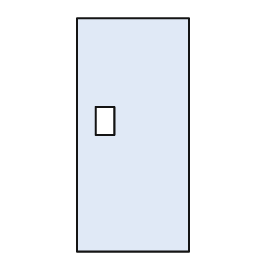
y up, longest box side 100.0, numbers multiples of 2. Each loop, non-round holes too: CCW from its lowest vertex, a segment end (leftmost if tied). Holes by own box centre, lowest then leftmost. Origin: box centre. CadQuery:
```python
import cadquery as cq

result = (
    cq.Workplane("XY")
    .moveTo(-24.0, -50.0)
    .lineTo(24.0, -50.0)
    .lineTo(24.0, 50.0)
    .lineTo(-24.0, 50.0)
    .close()
    .moveTo(-16.0, 0.0)
    .lineTo(-8.0, 0.0)
    .lineTo(-8.0, 12.0)
    .lineTo(-16.0, 12.0)
    .close()
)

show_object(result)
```